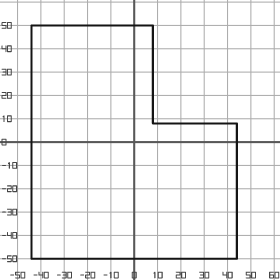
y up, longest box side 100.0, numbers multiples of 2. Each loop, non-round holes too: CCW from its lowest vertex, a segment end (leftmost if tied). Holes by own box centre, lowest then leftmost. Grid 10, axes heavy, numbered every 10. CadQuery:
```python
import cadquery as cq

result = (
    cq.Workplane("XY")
    .moveTo(-44.0, -50.0)
    .lineTo(44.0, -50.0)
    .lineTo(44.0, 8.0)
    .lineTo(8.0, 8.0)
    .lineTo(8.0, 50.0)
    .lineTo(-44.0, 50.0)
    .close()
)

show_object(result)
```